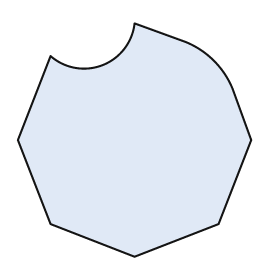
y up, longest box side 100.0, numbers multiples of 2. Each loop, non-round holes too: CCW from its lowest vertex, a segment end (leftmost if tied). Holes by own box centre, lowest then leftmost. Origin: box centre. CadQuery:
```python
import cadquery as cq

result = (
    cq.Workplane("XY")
    .moveTo(0.0, -50.0)
    .lineTo(36.0, -36.0)
    .lineTo(50.0, 0.0)
    .lineTo(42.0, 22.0)
    .threePointArc((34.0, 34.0), (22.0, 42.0))
    .lineTo(0.0, 50.0)
    .threePointArc((-14.0, 32.0), (-36.0, 36.0))
    .lineTo(-50.0, 0.0)
    .lineTo(-36.0, -36.0)
    .close()
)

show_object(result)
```